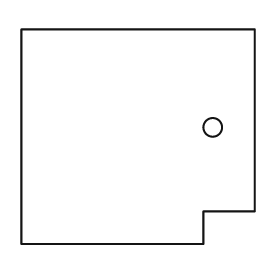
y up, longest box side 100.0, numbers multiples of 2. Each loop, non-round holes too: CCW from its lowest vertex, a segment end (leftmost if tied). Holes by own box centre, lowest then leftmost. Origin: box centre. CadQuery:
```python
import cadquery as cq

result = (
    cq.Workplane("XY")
    .moveTo(-50.0, -46.0)
    .lineTo(28.0, -46.0)
    .lineTo(28.0, -32.0)
    .lineTo(50.0, -32.0)
    .lineTo(50.0, 46.0)
    .lineTo(-50.0, 46.0)
    .close()
    .moveTo(32.0, 4.0)
    .circle(4.0)
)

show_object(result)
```